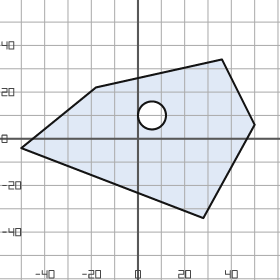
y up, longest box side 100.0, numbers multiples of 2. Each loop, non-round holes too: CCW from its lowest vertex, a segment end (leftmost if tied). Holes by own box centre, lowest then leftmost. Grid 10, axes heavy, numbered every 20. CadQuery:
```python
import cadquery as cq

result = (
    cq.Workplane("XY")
    .moveTo(28.0, -34.0)
    .lineTo(50.0, 6.0)
    .lineTo(36.0, 34.0)
    .lineTo(-18.0, 22.0)
    .lineTo(-50.0, -4.0)
    .close()
    .moveTo(6.0, 10.0)
    .circle(6.0)
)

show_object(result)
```